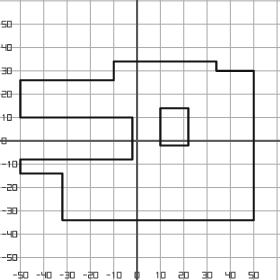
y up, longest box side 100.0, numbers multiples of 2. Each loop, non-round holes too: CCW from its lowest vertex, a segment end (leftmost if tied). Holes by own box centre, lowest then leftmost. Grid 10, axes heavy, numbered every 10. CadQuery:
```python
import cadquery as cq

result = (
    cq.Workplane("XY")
    .moveTo(-32.0, -34.0)
    .lineTo(50.0, -34.0)
    .lineTo(50.0, 30.0)
    .lineTo(34.0, 30.0)
    .lineTo(34.0, 34.0)
    .lineTo(-10.0, 34.0)
    .lineTo(-10.0, 26.0)
    .lineTo(-50.0, 26.0)
    .lineTo(-50.0, 10.0)
    .lineTo(-2.0, 10.0)
    .lineTo(-2.0, -8.0)
    .lineTo(-50.0, -8.0)
    .lineTo(-50.0, -14.0)
    .lineTo(-32.0, -14.0)
    .close()
    .moveTo(10.0, -2.0)
    .lineTo(22.0, -2.0)
    .lineTo(22.0, 14.0)
    .lineTo(10.0, 14.0)
    .close()
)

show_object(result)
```